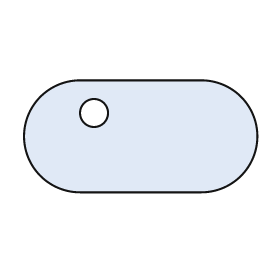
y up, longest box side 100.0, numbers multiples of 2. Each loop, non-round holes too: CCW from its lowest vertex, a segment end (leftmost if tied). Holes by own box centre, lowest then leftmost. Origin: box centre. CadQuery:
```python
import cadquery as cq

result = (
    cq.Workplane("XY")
    .moveTo(-26.0, -24.0)
    .lineTo(26.0, -24.0)
    .threePointArc((50.0, 0.0), (26.0, 24.0))
    .lineTo(-26.0, 24.0)
    .threePointArc((-50.0, 0.0), (-26.0, -24.0))
    .close()
    .moveTo(-20.0, 10.0)
    .circle(6.0)
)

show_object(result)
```